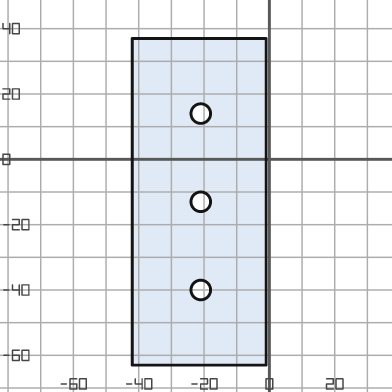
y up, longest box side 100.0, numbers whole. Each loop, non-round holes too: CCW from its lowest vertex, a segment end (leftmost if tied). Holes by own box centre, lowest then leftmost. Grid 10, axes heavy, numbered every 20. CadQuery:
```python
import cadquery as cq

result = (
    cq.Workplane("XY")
    .moveTo(-42.0, -63.0)
    .lineTo(-1.0, -63.0)
    .lineTo(-1.0, 37.0)
    .lineTo(-42.0, 37.0)
    .close()
    .moveTo(-21.0, -40.0)
    .circle(3.0)
    .moveTo(-21.0, -13.0)
    .circle(3.0)
    .moveTo(-21.0, 14.0)
    .circle(3.0)
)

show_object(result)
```